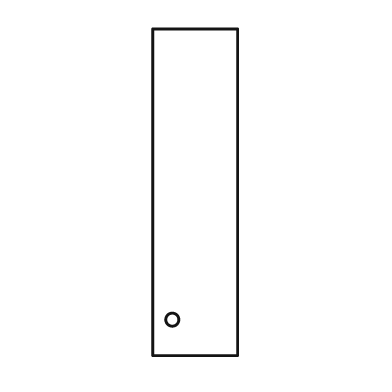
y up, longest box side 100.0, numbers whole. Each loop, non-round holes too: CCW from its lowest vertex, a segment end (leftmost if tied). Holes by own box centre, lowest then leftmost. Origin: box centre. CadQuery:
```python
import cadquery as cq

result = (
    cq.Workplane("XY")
    .moveTo(-13.0, -50.0)
    .lineTo(13.0, -50.0)
    .lineTo(13.0, 50.0)
    .lineTo(-13.0, 50.0)
    .close()
    .moveTo(-7.0, -39.0)
    .circle(2.0)
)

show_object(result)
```